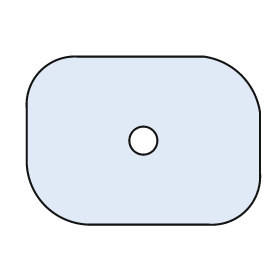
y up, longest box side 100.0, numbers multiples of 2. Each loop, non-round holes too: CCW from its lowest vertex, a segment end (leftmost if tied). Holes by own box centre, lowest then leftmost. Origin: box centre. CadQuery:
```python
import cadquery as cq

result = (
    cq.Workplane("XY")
    .moveTo(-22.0, -36.0)
    .lineTo(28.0, -36.0)
    .threePointArc((44.0, -30.0), (50.0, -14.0))
    .lineTo(50.0, 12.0)
    .threePointArc((42.0, 28.0), (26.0, 36.0))
    .lineTo(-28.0, 36.0)
    .threePointArc((-44.0, 30.0), (-50.0, 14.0))
    .lineTo(-50.0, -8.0)
    .threePointArc((-42.0, -28.0), (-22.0, -36.0))
    .close()
    .moveTo(0.0, 0.0)
    .circle(6.0)
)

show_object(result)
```